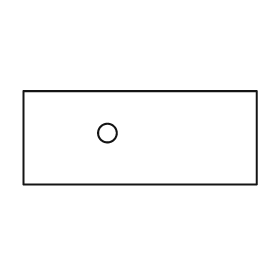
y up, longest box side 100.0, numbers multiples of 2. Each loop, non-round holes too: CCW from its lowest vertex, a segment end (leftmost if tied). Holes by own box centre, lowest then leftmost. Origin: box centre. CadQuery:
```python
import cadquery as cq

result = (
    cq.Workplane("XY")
    .moveTo(-50.0, -20.0)
    .lineTo(50.0, -20.0)
    .lineTo(50.0, 20.0)
    .lineTo(-50.0, 20.0)
    .close()
    .moveTo(-14.0, 2.0)
    .circle(4.0)
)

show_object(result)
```